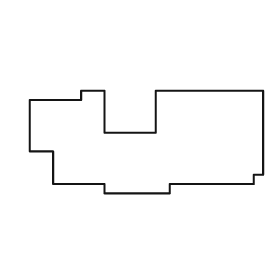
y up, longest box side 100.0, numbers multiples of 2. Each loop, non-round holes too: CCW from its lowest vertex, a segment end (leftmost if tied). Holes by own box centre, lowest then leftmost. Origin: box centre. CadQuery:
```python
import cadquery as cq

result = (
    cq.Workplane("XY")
    .moveTo(-18.0, -22.0)
    .lineTo(10.0, -22.0)
    .lineTo(10.0, -18.0)
    .lineTo(46.0, -18.0)
    .lineTo(46.0, -14.0)
    .lineTo(50.0, -14.0)
    .lineTo(50.0, 22.0)
    .lineTo(4.0, 22.0)
    .lineTo(4.0, 4.0)
    .lineTo(-18.0, 4.0)
    .lineTo(-18.0, 22.0)
    .lineTo(-28.0, 22.0)
    .lineTo(-28.0, 18.0)
    .lineTo(-50.0, 18.0)
    .lineTo(-50.0, -4.0)
    .lineTo(-40.0, -4.0)
    .lineTo(-40.0, -18.0)
    .lineTo(-18.0, -18.0)
    .close()
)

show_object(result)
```